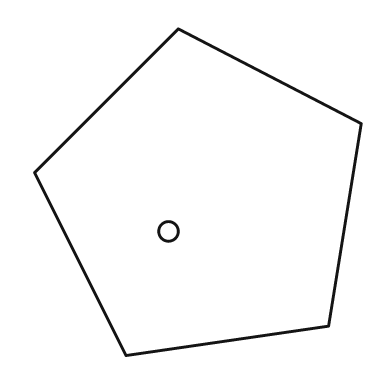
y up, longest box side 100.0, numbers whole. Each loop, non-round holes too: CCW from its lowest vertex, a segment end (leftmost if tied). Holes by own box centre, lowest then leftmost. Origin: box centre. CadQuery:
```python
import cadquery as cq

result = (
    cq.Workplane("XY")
    .moveTo(-22.0, -50.0)
    .lineTo(40.0, -41.0)
    .lineTo(50.0, 21.0)
    .lineTo(-6.0, 50.0)
    .lineTo(-50.0, 6.0)
    .close()
    .moveTo(-9.0, -12.0)
    .circle(3.0)
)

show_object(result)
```